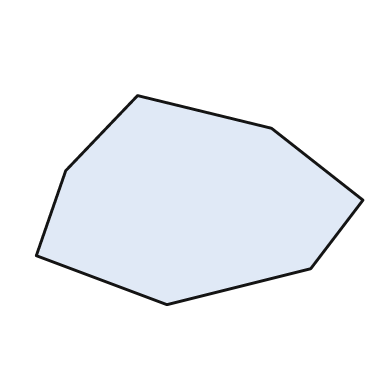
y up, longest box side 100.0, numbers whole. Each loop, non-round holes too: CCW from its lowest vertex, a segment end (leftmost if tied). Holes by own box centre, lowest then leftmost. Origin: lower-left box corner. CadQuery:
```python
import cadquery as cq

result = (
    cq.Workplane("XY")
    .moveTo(40.0, 0.0)
    .lineTo(84.0, 11.0)
    .lineTo(100.0, 32.0)
    .lineTo(72.0, 54.0)
    .lineTo(31.0, 64.0)
    .lineTo(9.0, 41.0)
    .lineTo(0.0, 15.0)
    .close()
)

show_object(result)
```